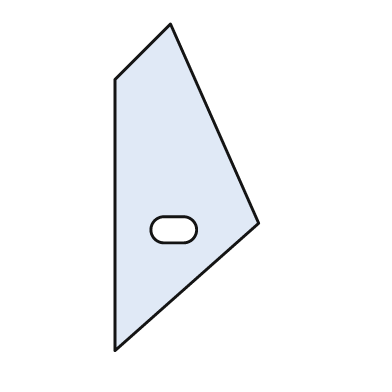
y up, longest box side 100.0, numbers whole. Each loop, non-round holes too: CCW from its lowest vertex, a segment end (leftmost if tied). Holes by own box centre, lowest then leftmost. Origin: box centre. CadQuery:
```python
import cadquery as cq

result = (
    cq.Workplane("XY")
    .moveTo(-22.0, -50.0)
    .lineTo(22.0, -11.0)
    .lineTo(-5.0, 50.0)
    .lineTo(-22.0, 33.0)
    .close()
    .moveTo(-7.0, -17.0)
    .lineTo(-1.0, -17.0)
    .threePointArc((3.0, -13.0), (-1.0, -9.0))
    .lineTo(-7.0, -9.0)
    .threePointArc((-11.0, -13.0), (-7.0, -17.0))
    .close()
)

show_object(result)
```